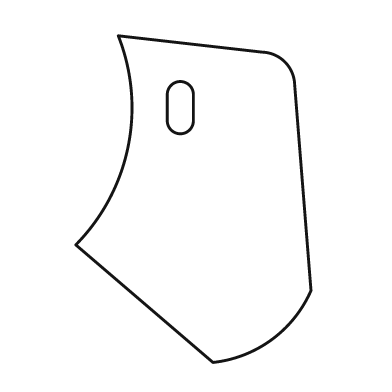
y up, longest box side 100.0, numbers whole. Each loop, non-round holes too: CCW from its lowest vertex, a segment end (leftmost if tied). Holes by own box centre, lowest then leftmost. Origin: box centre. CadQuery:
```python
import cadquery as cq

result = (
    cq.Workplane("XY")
    .moveTo(6.0, -50.0)
    .threePointArc((24.0, -43.0), (36.0, -28.0))
    .lineTo(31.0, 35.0)
    .threePointArc((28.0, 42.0), (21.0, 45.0))
    .lineTo(-23.0, 50.0)
    .threePointArc((-20.0, 16.0), (-36.0, -14.0))
    .close()
    .moveTo(-8.0, 24.0)
    .threePointArc((-4.0, 20.0), (0.0, 24.0))
    .lineTo(0.0, 32.0)
    .threePointArc((-4.0, 36.0), (-8.0, 32.0))
    .close()
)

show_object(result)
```